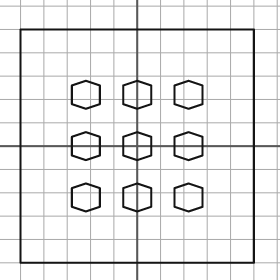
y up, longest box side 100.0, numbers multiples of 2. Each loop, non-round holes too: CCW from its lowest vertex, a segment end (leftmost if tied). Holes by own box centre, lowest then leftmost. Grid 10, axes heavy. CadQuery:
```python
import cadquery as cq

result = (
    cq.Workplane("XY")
    .moveTo(-50.0, -50.0)
    .lineTo(50.0, -50.0)
    .lineTo(50.0, 50.0)
    .lineTo(-50.0, 50.0)
    .close()
    .moveTo(-22.0, -28.0)
    .lineTo(-16.0, -26.0)
    .lineTo(-16.0, -18.0)
    .lineTo(-22.0, -16.0)
    .lineTo(-28.0, -18.0)
    .lineTo(-28.0, -26.0)
    .close()
    .moveTo(0.0, -28.0)
    .lineTo(6.0, -26.0)
    .lineTo(6.0, -18.0)
    .lineTo(0.0, -16.0)
    .lineTo(-6.0, -18.0)
    .lineTo(-6.0, -26.0)
    .close()
    .moveTo(22.0, -28.0)
    .lineTo(28.0, -26.0)
    .lineTo(28.0, -18.0)
    .lineTo(22.0, -16.0)
    .lineTo(16.0, -18.0)
    .lineTo(16.0, -26.0)
    .close()
    .moveTo(-22.0, -6.0)
    .lineTo(-16.0, -4.0)
    .lineTo(-16.0, 4.0)
    .lineTo(-22.0, 6.0)
    .lineTo(-28.0, 4.0)
    .lineTo(-28.0, -4.0)
    .close()
    .moveTo(0.0, -6.0)
    .lineTo(6.0, -4.0)
    .lineTo(6.0, 4.0)
    .lineTo(0.0, 6.0)
    .lineTo(-6.0, 4.0)
    .lineTo(-6.0, -4.0)
    .close()
    .moveTo(22.0, -6.0)
    .lineTo(28.0, -4.0)
    .lineTo(28.0, 4.0)
    .lineTo(22.0, 6.0)
    .lineTo(16.0, 4.0)
    .lineTo(16.0, -4.0)
    .close()
    .moveTo(-22.0, 16.0)
    .lineTo(-16.0, 18.0)
    .lineTo(-16.0, 26.0)
    .lineTo(-22.0, 28.0)
    .lineTo(-28.0, 26.0)
    .lineTo(-28.0, 18.0)
    .close()
    .moveTo(0.0, 16.0)
    .lineTo(6.0, 18.0)
    .lineTo(6.0, 26.0)
    .lineTo(0.0, 28.0)
    .lineTo(-6.0, 26.0)
    .lineTo(-6.0, 18.0)
    .close()
    .moveTo(22.0, 16.0)
    .lineTo(28.0, 18.0)
    .lineTo(28.0, 26.0)
    .lineTo(22.0, 28.0)
    .lineTo(16.0, 26.0)
    .lineTo(16.0, 18.0)
    .close()
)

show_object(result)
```